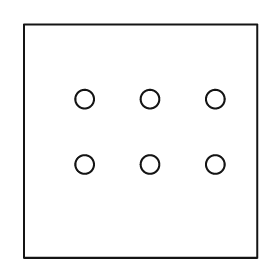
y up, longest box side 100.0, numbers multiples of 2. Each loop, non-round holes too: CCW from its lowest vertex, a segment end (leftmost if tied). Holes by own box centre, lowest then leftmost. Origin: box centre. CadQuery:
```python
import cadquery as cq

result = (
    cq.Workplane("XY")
    .moveTo(-50.0, -50.0)
    .lineTo(50.0, -50.0)
    .lineTo(50.0, 50.0)
    .lineTo(-50.0, 50.0)
    .close()
    .moveTo(-24.0, -10.0)
    .circle(4.0)
    .moveTo(4.0, -10.0)
    .circle(4.0)
    .moveTo(32.0, -10.0)
    .circle(4.0)
    .moveTo(-24.0, 18.0)
    .circle(4.0)
    .moveTo(4.0, 18.0)
    .circle(4.0)
    .moveTo(32.0, 18.0)
    .circle(4.0)
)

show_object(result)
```